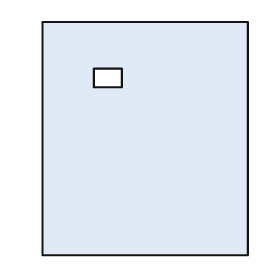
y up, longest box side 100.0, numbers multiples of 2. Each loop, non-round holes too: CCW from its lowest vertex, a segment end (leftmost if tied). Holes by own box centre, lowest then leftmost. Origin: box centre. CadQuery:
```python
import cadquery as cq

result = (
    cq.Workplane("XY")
    .moveTo(-44.0, -50.0)
    .lineTo(44.0, -50.0)
    .lineTo(44.0, 50.0)
    .lineTo(-44.0, 50.0)
    .close()
    .moveTo(-22.0, 22.0)
    .lineTo(-10.0, 22.0)
    .lineTo(-10.0, 30.0)
    .lineTo(-22.0, 30.0)
    .close()
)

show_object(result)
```